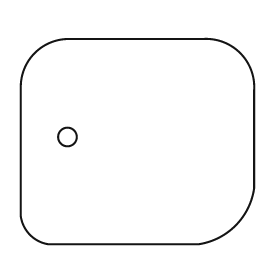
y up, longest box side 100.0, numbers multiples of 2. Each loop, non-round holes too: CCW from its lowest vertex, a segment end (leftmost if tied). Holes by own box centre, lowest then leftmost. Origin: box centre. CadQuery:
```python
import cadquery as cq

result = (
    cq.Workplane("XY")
    .moveTo(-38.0, -44.0)
    .lineTo(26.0, -44.0)
    .threePointArc((42.0, -36.0), (50.0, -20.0))
    .lineTo(50.0, 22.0)
    .threePointArc((44.0, 38.0), (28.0, 44.0))
    .lineTo(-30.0, 44.0)
    .threePointArc((-44.0, 38.0), (-50.0, 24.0))
    .lineTo(-50.0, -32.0)
    .threePointArc((-46.0, -40.0), (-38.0, -44.0))
    .close()
    .moveTo(-30.0, 2.0)
    .circle(4.0)
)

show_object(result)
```